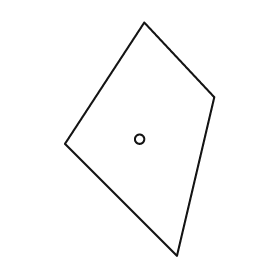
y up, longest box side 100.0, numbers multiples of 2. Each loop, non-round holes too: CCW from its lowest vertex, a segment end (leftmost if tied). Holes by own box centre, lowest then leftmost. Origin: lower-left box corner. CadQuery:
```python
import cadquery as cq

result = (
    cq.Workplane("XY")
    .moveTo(48.0, 0.0)
    .lineTo(64.0, 68.0)
    .lineTo(34.0, 100.0)
    .lineTo(0.0, 48.0)
    .close()
    .moveTo(32.0, 50.0)
    .circle(2.0)
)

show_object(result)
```